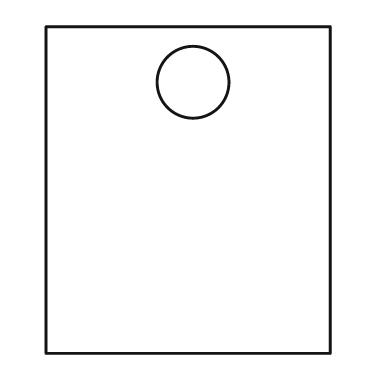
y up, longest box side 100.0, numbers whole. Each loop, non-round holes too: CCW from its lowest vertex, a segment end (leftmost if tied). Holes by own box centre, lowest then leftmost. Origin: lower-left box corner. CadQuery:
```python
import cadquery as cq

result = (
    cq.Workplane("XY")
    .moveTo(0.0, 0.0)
    .lineTo(87.0, 0.0)
    .lineTo(87.0, 100.0)
    .lineTo(0.0, 100.0)
    .close()
    .moveTo(45.0, 83.0)
    .circle(11.0)
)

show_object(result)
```